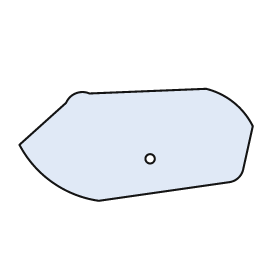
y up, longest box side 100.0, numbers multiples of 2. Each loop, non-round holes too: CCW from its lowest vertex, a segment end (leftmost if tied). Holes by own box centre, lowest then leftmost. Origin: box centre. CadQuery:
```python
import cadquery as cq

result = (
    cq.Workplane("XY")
    .moveTo(-16.0, -24.0)
    .lineTo(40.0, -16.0)
    .threePointArc((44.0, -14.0), (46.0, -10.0))
    .lineTo(50.0, 8.0)
    .threePointArc((42.0, 18.0), (30.0, 24.0))
    .lineTo(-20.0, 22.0)
    .threePointArc((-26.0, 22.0), (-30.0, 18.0))
    .lineTo(-50.0, 0.0)
    .threePointArc((-36.0, -16.0), (-16.0, -24.0))
    .close()
    .moveTo(6.0, -6.0)
    .circle(2.0)
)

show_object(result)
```